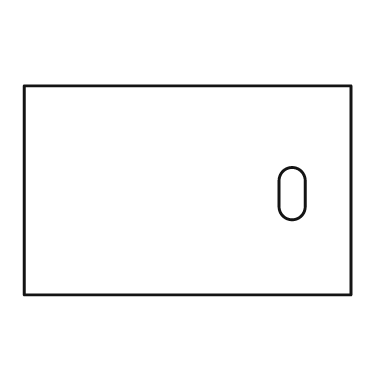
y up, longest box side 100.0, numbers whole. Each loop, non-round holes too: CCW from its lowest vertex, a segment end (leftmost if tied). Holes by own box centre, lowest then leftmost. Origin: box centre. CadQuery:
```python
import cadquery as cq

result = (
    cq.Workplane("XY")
    .moveTo(-50.0, -32.0)
    .lineTo(50.0, -32.0)
    .lineTo(50.0, 32.0)
    .lineTo(-50.0, 32.0)
    .close()
    .moveTo(28.0, -5.0)
    .threePointArc((32.0, -9.0), (36.0, -5.0))
    .lineTo(36.0, 3.0)
    .threePointArc((32.0, 7.0), (28.0, 3.0))
    .close()
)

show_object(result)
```